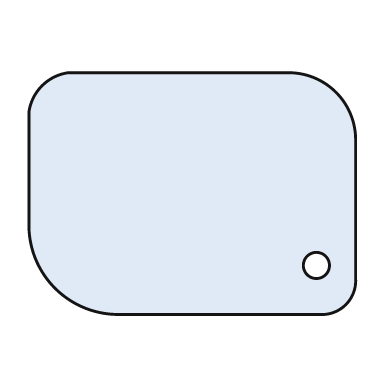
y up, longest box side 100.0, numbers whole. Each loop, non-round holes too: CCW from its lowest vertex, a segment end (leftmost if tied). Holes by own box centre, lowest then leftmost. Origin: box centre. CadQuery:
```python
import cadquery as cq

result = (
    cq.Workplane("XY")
    .moveTo(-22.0, -37.0)
    .lineTo(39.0, -37.0)
    .threePointArc((47.0, -34.0), (50.0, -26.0))
    .lineTo(50.0, 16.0)
    .threePointArc((44.0, 31.0), (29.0, 37.0))
    .lineTo(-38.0, 37.0)
    .threePointArc((-46.0, 33.0), (-50.0, 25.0))
    .lineTo(-50.0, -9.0)
    .threePointArc((-42.0, -29.0), (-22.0, -37.0))
    .close()
    .moveTo(38.0, -22.0)
    .circle(4.0)
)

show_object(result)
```